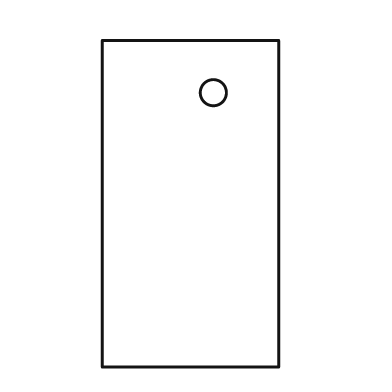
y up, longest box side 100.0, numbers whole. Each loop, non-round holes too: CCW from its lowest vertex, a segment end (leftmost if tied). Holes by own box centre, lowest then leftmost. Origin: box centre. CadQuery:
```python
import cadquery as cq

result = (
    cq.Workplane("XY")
    .moveTo(-27.0, -50.0)
    .lineTo(27.0, -50.0)
    .lineTo(27.0, 50.0)
    .lineTo(-27.0, 50.0)
    .close()
    .moveTo(7.0, 34.0)
    .circle(4.0)
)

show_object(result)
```